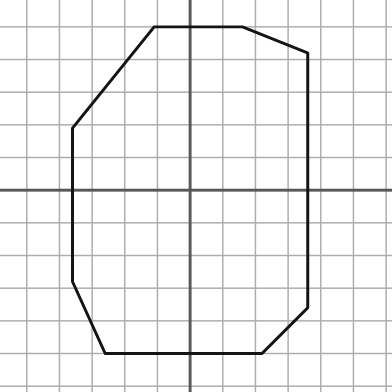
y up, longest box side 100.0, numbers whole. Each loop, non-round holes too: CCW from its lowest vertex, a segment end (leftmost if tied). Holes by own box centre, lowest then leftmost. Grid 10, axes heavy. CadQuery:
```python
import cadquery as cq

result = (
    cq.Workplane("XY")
    .moveTo(-26.0, -50.0)
    .lineTo(22.0, -50.0)
    .lineTo(36.0, -36.0)
    .lineTo(36.0, 42.0)
    .lineTo(16.0, 50.0)
    .lineTo(-11.0, 50.0)
    .lineTo(-36.0, 19.0)
    .lineTo(-36.0, -28.0)
    .close()
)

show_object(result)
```